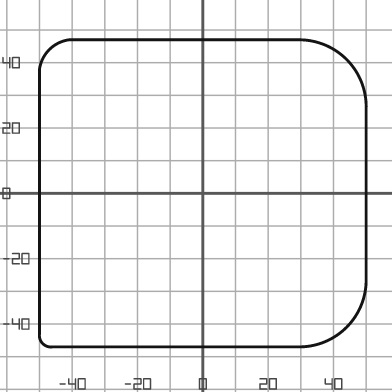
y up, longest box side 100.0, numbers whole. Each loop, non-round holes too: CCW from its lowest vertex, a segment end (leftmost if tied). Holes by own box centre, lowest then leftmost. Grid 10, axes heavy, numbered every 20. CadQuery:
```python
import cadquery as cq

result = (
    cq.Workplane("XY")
    .moveTo(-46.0, -47.0)
    .lineTo(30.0, -47.0)
    .threePointArc((44.0, -41.0), (50.0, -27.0))
    .lineTo(50.0, 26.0)
    .threePointArc((44.0, 41.0), (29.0, 47.0))
    .lineTo(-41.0, 47.0)
    .threePointArc((-47.0, 44.0), (-50.0, 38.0))
    .lineTo(-50.0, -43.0)
    .threePointArc((-49.0, -46.0), (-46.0, -47.0))
    .close()
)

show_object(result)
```